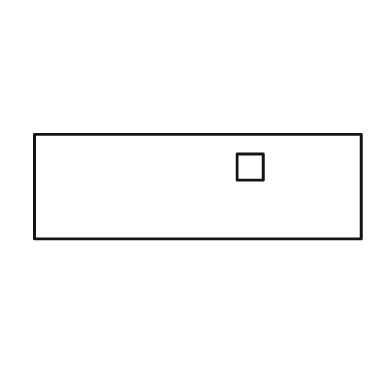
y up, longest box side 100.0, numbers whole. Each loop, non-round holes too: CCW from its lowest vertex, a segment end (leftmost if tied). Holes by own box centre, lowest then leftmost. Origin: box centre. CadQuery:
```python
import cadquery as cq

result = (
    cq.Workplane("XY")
    .moveTo(-50.0, -16.0)
    .lineTo(50.0, -16.0)
    .lineTo(50.0, 16.0)
    .lineTo(-50.0, 16.0)
    .close()
    .moveTo(12.0, 2.0)
    .lineTo(20.0, 2.0)
    .lineTo(20.0, 10.0)
    .lineTo(12.0, 10.0)
    .close()
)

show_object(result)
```